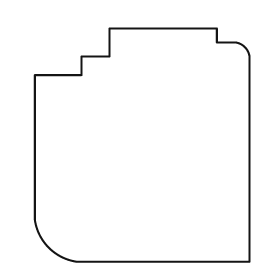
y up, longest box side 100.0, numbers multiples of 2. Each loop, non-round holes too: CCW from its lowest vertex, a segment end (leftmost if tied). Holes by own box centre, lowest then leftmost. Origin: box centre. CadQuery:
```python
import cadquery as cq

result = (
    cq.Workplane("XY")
    .moveTo(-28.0, -50.0)
    .lineTo(46.0, -50.0)
    .lineTo(46.0, 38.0)
    .threePointArc((44.0, 42.0), (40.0, 44.0))
    .lineTo(32.0, 44.0)
    .lineTo(32.0, 50.0)
    .lineTo(-14.0, 50.0)
    .lineTo(-14.0, 38.0)
    .lineTo(-26.0, 38.0)
    .lineTo(-26.0, 30.0)
    .lineTo(-46.0, 30.0)
    .lineTo(-46.0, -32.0)
    .threePointArc((-40.0, -44.0), (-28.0, -50.0))
    .close()
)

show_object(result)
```